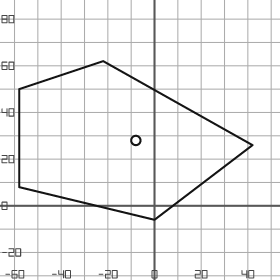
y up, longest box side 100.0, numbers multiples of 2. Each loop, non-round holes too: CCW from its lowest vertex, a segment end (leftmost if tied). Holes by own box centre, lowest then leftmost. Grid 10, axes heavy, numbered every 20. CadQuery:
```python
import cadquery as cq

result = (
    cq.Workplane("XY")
    .moveTo(0.0, -6.0)
    .lineTo(42.0, 26.0)
    .lineTo(-22.0, 62.0)
    .lineTo(-58.0, 50.0)
    .lineTo(-58.0, 8.0)
    .close()
    .moveTo(-8.0, 28.0)
    .circle(2.0)
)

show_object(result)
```